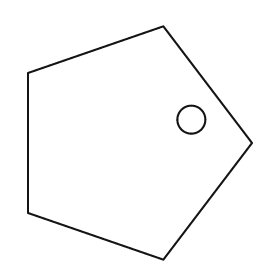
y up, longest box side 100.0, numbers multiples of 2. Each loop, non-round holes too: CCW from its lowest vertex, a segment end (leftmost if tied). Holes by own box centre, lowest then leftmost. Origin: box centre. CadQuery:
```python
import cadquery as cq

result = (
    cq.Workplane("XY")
    .moveTo(10.0, -50.0)
    .lineTo(48.0, 0.0)
    .lineTo(10.0, 50.0)
    .lineTo(-48.0, 30.0)
    .lineTo(-48.0, -30.0)
    .close()
    .moveTo(22.0, 10.0)
    .circle(6.0)
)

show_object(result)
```